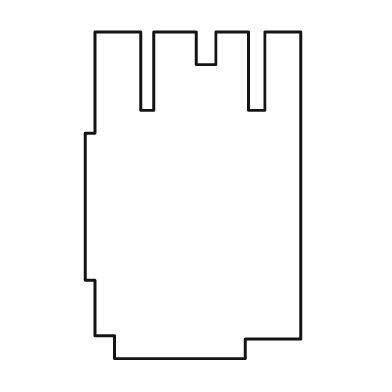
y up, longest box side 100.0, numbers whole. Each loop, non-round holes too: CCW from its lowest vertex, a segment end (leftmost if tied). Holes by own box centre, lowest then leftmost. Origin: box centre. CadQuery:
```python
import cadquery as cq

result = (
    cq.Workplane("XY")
    .moveTo(-24.0, -50.0)
    .lineTo(16.0, -50.0)
    .lineTo(16.0, -44.0)
    .lineTo(33.0, -44.0)
    .lineTo(33.0, 50.0)
    .lineTo(22.0, 50.0)
    .lineTo(22.0, 26.0)
    .lineTo(17.0, 26.0)
    .lineTo(17.0, 50.0)
    .lineTo(7.0, 50.0)
    .lineTo(7.0, 40.0)
    .lineTo(1.0, 40.0)
    .lineTo(1.0, 50.0)
    .lineTo(-12.0, 50.0)
    .lineTo(-12.0, 26.0)
    .lineTo(-16.0, 26.0)
    .lineTo(-16.0, 50.0)
    .lineTo(-30.0, 50.0)
    .lineTo(-30.0, 19.0)
    .lineTo(-33.0, 19.0)
    .lineTo(-33.0, -26.0)
    .lineTo(-30.0, -26.0)
    .lineTo(-30.0, -43.0)
    .lineTo(-24.0, -43.0)
    .close()
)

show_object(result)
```